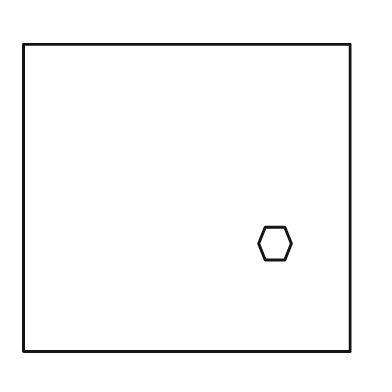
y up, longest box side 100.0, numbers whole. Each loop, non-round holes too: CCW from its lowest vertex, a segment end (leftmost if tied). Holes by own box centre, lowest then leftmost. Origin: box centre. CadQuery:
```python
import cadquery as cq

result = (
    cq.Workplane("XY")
    .moveTo(-50.0, -47.0)
    .lineTo(50.0, -47.0)
    .lineTo(50.0, 47.0)
    .lineTo(-50.0, 47.0)
    .close()
    .moveTo(24.0, -19.0)
    .lineTo(30.0, -19.0)
    .lineTo(32.0, -14.0)
    .lineTo(30.0, -9.0)
    .lineTo(24.0, -9.0)
    .lineTo(22.0, -14.0)
    .close()
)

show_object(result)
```